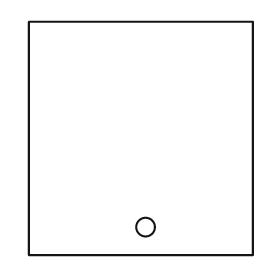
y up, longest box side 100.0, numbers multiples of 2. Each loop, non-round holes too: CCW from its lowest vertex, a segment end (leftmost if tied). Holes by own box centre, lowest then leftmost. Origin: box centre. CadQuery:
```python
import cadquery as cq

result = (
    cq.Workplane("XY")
    .moveTo(-48.0, -50.0)
    .lineTo(48.0, -50.0)
    .lineTo(48.0, 50.0)
    .lineTo(-48.0, 50.0)
    .close()
    .moveTo(2.0, -38.0)
    .circle(4.0)
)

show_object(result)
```